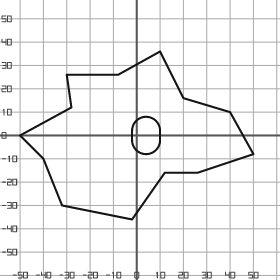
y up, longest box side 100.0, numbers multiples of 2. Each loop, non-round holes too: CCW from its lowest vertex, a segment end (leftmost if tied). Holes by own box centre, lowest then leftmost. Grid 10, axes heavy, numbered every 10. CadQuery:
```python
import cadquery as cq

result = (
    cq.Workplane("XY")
    .moveTo(-2.0, -36.0)
    .lineTo(12.0, -16.0)
    .lineTo(26.0, -16.0)
    .lineTo(50.0, -8.0)
    .lineTo(40.0, 10.0)
    .lineTo(20.0, 16.0)
    .lineTo(10.0, 36.0)
    .lineTo(-8.0, 26.0)
    .lineTo(-30.0, 26.0)
    .lineTo(-28.0, 12.0)
    .lineTo(-50.0, 0.0)
    .lineTo(-40.0, -10.0)
    .lineTo(-32.0, -30.0)
    .close()
    .moveTo(-2.0, -2.0)
    .threePointArc((4.0, -8.0), (10.0, -2.0))
    .lineTo(10.0, 2.0)
    .threePointArc((4.0, 8.0), (-2.0, 2.0))
    .close()
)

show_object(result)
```